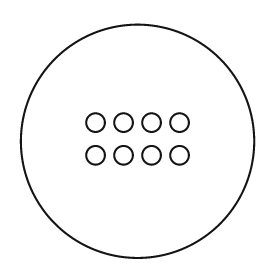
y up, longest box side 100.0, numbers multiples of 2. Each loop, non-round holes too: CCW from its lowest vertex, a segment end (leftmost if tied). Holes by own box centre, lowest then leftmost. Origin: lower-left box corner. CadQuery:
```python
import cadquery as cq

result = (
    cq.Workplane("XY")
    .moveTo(50.0, 50.0)
    .circle(50.0)
    .moveTo(32.0, 44.0)
    .circle(4.0)
    .moveTo(44.0, 44.0)
    .circle(4.0)
    .moveTo(56.0, 44.0)
    .circle(4.0)
    .moveTo(68.0, 44.0)
    .circle(4.0)
    .moveTo(32.0, 58.0)
    .circle(4.0)
    .moveTo(44.0, 58.0)
    .circle(4.0)
    .moveTo(56.0, 58.0)
    .circle(4.0)
    .moveTo(68.0, 58.0)
    .circle(4.0)
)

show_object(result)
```